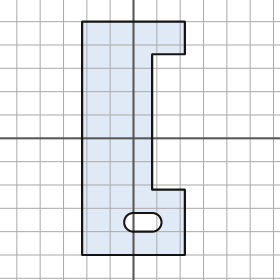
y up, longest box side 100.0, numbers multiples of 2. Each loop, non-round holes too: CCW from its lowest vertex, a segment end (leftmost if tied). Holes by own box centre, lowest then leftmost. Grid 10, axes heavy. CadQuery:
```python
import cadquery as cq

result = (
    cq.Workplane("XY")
    .moveTo(-22.0, -50.0)
    .lineTo(22.0, -50.0)
    .lineTo(22.0, -22.0)
    .lineTo(8.0, -22.0)
    .lineTo(8.0, 36.0)
    .lineTo(22.0, 36.0)
    .lineTo(22.0, 50.0)
    .lineTo(-22.0, 50.0)
    .close()
    .moveTo(0.0, -40.0)
    .lineTo(8.0, -40.0)
    .threePointArc((12.0, -36.0), (8.0, -32.0))
    .lineTo(0.0, -32.0)
    .threePointArc((-4.0, -36.0), (0.0, -40.0))
    .close()
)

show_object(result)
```